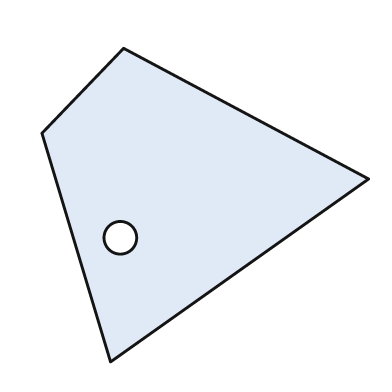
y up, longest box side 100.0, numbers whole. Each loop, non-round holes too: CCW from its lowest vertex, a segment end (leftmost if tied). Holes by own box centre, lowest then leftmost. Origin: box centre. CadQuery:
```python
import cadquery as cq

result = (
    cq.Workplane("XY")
    .moveTo(-29.0, -48.0)
    .lineTo(50.0, 8.0)
    .lineTo(-25.0, 48.0)
    .lineTo(-50.0, 22.0)
    .close()
    .moveTo(-26.0, -10.0)
    .circle(5.0)
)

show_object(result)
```